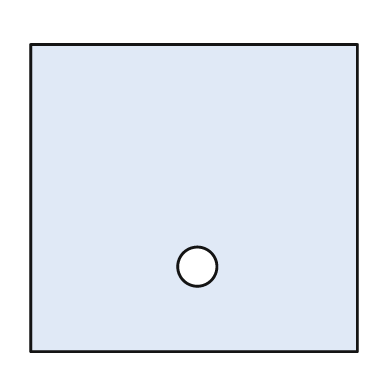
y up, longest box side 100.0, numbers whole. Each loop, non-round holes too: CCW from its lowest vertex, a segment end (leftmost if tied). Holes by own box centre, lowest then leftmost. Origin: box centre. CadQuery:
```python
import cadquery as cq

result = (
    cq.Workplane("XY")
    .moveTo(-50.0, -47.0)
    .lineTo(50.0, -47.0)
    .lineTo(50.0, 47.0)
    .lineTo(-50.0, 47.0)
    .close()
    .moveTo(1.0, -21.0)
    .circle(6.0)
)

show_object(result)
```